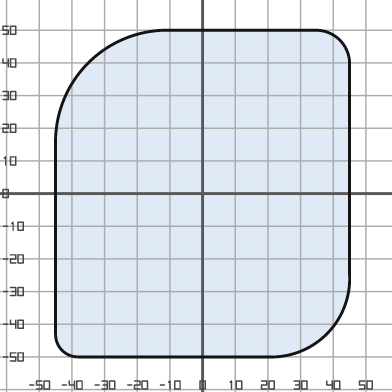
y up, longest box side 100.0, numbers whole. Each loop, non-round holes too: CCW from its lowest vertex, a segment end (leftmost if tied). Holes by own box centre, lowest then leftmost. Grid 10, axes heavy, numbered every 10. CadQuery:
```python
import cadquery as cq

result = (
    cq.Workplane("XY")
    .moveTo(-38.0, -50.0)
    .lineTo(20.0, -50.0)
    .threePointArc((38.0, -43.0), (45.0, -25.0))
    .lineTo(45.0, 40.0)
    .threePointArc((42.0, 47.0), (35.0, 50.0))
    .lineTo(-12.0, 50.0)
    .threePointArc((-35.0, 40.0), (-45.0, 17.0))
    .lineTo(-45.0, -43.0)
    .threePointArc((-43.0, -48.0), (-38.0, -50.0))
    .close()
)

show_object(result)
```